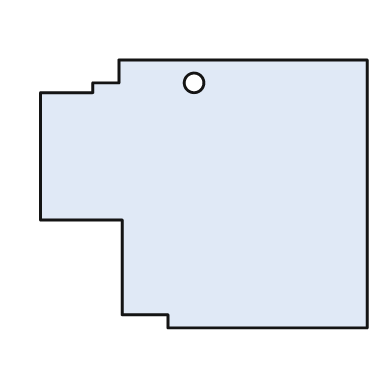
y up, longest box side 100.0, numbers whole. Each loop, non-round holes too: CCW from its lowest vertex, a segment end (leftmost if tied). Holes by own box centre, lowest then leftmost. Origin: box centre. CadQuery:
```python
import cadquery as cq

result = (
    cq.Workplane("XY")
    .moveTo(-11.0, -41.0)
    .lineTo(50.0, -41.0)
    .lineTo(50.0, 41.0)
    .lineTo(-26.0, 41.0)
    .lineTo(-26.0, 34.0)
    .lineTo(-34.0, 34.0)
    .lineTo(-34.0, 31.0)
    .lineTo(-50.0, 31.0)
    .lineTo(-50.0, -8.0)
    .lineTo(-25.0, -8.0)
    .lineTo(-25.0, -37.0)
    .lineTo(-11.0, -37.0)
    .close()
    .moveTo(-3.0, 34.0)
    .circle(3.0)
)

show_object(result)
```